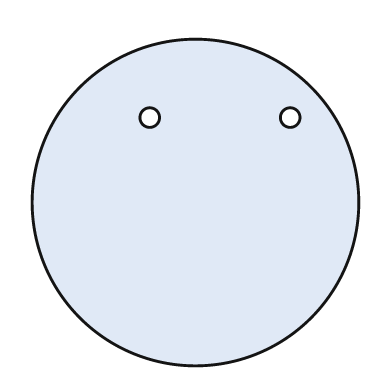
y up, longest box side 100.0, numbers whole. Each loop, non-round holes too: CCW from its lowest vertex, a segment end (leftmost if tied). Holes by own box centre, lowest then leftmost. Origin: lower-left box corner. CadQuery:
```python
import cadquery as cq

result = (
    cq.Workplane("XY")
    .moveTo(50.0, 50.0)
    .circle(50.0)
    .moveTo(36.0, 76.0)
    .circle(3.0)
    .moveTo(79.0, 76.0)
    .circle(3.0)
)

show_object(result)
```